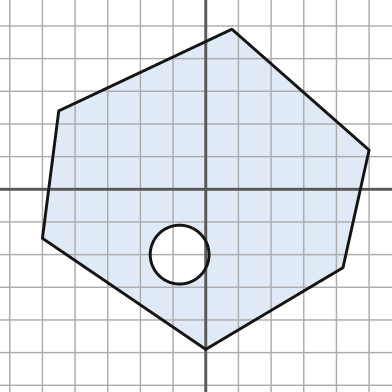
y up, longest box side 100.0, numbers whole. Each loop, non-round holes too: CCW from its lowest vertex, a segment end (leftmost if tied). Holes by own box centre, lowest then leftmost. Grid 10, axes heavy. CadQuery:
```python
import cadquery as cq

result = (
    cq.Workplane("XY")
    .moveTo(0.0, -49.0)
    .lineTo(42.0, -24.0)
    .lineTo(50.0, 12.0)
    .lineTo(8.0, 49.0)
    .lineTo(-45.0, 24.0)
    .lineTo(-50.0, -15.0)
    .close()
    .moveTo(-8.0, -20.0)
    .circle(9.0)
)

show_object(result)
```